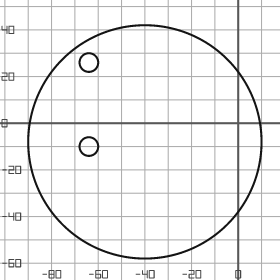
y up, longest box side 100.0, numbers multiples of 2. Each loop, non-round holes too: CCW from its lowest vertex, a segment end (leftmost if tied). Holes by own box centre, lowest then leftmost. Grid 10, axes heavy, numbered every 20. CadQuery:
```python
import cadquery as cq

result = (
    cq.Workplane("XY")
    .moveTo(-40.0, -8.0)
    .circle(50.0)
    .moveTo(-64.0, -10.0)
    .circle(4.0)
    .moveTo(-64.0, 26.0)
    .circle(4.0)
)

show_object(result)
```